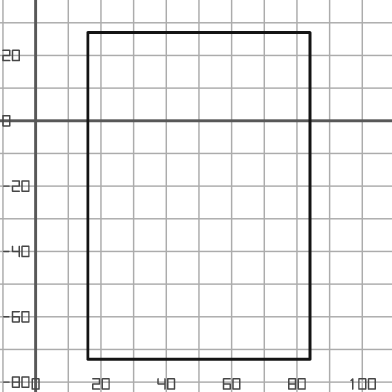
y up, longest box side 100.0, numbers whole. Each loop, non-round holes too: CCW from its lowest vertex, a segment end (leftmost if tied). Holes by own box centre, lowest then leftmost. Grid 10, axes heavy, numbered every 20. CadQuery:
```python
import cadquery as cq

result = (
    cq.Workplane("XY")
    .moveTo(16.0, -73.0)
    .lineTo(84.0, -73.0)
    .lineTo(84.0, 27.0)
    .lineTo(16.0, 27.0)
    .close()
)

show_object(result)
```